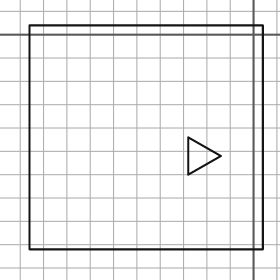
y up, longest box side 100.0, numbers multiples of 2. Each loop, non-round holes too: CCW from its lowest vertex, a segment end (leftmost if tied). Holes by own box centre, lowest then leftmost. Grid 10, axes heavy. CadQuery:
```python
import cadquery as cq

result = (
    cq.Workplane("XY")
    .moveTo(-96.0, -92.0)
    .lineTo(4.0, -92.0)
    .lineTo(4.0, 4.0)
    .lineTo(-96.0, 4.0)
    .close()
    .moveTo(-28.0, -60.0)
    .lineTo(-14.0, -52.0)
    .lineTo(-28.0, -44.0)
    .close()
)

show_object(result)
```